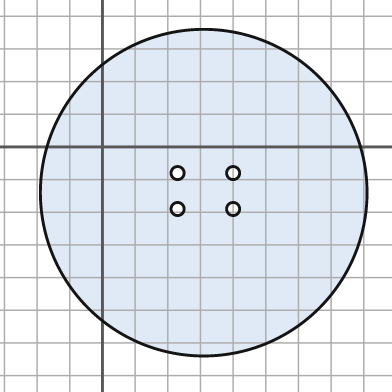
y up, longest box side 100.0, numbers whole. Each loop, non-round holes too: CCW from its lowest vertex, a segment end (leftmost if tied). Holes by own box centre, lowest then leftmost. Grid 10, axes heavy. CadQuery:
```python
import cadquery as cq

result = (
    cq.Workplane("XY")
    .moveTo(31.0, -14.0)
    .circle(50.0)
    .moveTo(23.0, -19.0)
    .circle(2.0)
    .moveTo(40.0, -19.0)
    .circle(2.0)
    .moveTo(23.0, -8.0)
    .circle(2.0)
    .moveTo(40.0, -8.0)
    .circle(2.0)
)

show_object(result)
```